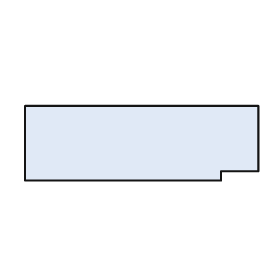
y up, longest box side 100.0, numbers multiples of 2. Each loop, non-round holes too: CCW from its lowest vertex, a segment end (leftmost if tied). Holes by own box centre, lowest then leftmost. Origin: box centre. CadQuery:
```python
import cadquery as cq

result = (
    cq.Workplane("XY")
    .moveTo(-50.0, -16.0)
    .lineTo(34.0, -16.0)
    .lineTo(34.0, -12.0)
    .lineTo(50.0, -12.0)
    .lineTo(50.0, 16.0)
    .lineTo(-50.0, 16.0)
    .close()
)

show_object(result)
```